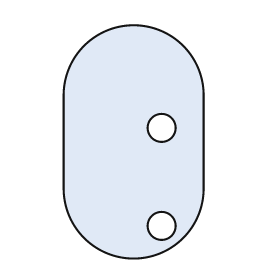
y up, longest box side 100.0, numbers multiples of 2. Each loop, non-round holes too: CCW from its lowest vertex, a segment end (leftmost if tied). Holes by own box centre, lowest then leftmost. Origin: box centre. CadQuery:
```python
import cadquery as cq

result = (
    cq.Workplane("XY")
    .moveTo(-30.0, -20.0)
    .threePointArc((0.0, -50.0), (30.0, -20.0))
    .lineTo(30.0, 20.0)
    .threePointArc((0.0, 50.0), (-30.0, 20.0))
    .close()
    .moveTo(12.0, -36.0)
    .circle(6.0)
    .moveTo(12.0, 6.0)
    .circle(6.0)
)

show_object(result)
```